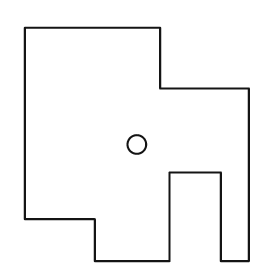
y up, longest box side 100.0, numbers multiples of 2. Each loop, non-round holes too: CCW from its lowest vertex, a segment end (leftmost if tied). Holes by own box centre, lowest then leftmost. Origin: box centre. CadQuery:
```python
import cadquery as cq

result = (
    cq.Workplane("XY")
    .moveTo(-18.0, -50.0)
    .lineTo(14.0, -50.0)
    .lineTo(14.0, -12.0)
    .lineTo(36.0, -12.0)
    .lineTo(36.0, -50.0)
    .lineTo(48.0, -50.0)
    .lineTo(48.0, 24.0)
    .lineTo(10.0, 24.0)
    .lineTo(10.0, 50.0)
    .lineTo(-48.0, 50.0)
    .lineTo(-48.0, -32.0)
    .lineTo(-18.0, -32.0)
    .close()
    .moveTo(0.0, 0.0)
    .circle(4.0)
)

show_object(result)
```